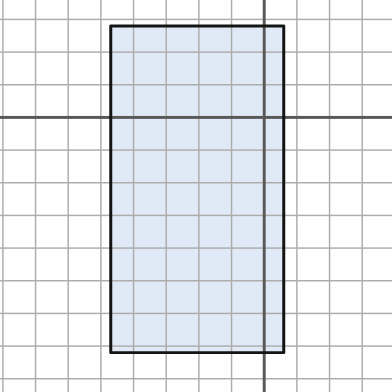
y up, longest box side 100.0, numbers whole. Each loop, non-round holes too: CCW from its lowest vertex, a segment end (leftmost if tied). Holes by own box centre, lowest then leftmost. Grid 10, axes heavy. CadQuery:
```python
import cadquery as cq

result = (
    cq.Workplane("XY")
    .moveTo(-47.0, -72.0)
    .lineTo(6.0, -72.0)
    .lineTo(6.0, 28.0)
    .lineTo(-47.0, 28.0)
    .close()
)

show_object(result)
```